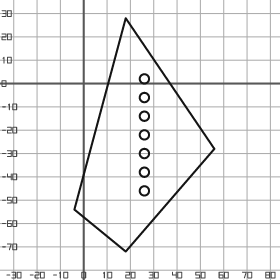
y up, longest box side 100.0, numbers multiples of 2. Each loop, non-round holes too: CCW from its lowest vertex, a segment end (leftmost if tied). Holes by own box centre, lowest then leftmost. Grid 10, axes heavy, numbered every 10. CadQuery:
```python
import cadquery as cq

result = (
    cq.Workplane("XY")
    .moveTo(18.0, -72.0)
    .lineTo(56.0, -28.0)
    .lineTo(18.0, 28.0)
    .lineTo(-4.0, -54.0)
    .close()
    .moveTo(26.0, -46.0)
    .circle(2.0)
    .moveTo(26.0, -38.0)
    .circle(2.0)
    .moveTo(26.0, -30.0)
    .circle(2.0)
    .moveTo(26.0, -22.0)
    .circle(2.0)
    .moveTo(26.0, -14.0)
    .circle(2.0)
    .moveTo(26.0, -6.0)
    .circle(2.0)
    .moveTo(26.0, 2.0)
    .circle(2.0)
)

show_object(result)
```